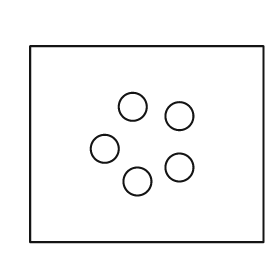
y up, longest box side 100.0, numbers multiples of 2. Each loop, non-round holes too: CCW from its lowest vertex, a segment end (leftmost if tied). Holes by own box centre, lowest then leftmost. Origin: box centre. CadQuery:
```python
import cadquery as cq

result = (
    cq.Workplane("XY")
    .moveTo(-50.0, -42.0)
    .lineTo(50.0, -42.0)
    .lineTo(50.0, 42.0)
    .lineTo(-50.0, 42.0)
    .close()
    .moveTo(-4.0, -16.0)
    .circle(6.0)
    .moveTo(14.0, -10.0)
    .circle(6.0)
    .moveTo(-18.0, -2.0)
    .circle(6.0)
    .moveTo(14.0, 12.0)
    .circle(6.0)
    .moveTo(-6.0, 16.0)
    .circle(6.0)
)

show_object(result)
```